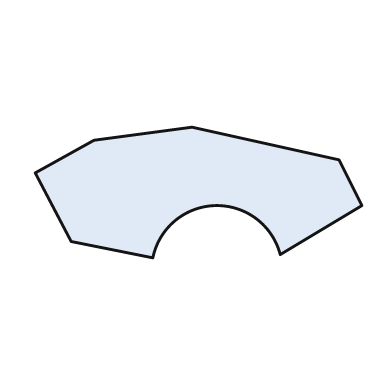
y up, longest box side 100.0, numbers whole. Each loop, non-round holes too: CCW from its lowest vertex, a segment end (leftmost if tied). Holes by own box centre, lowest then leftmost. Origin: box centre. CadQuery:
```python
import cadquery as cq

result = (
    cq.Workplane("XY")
    .moveTo(-14.0, -20.0)
    .threePointArc((5.0, -4.0), (25.0, -19.0))
    .lineTo(50.0, -4.0)
    .lineTo(43.0, 10.0)
    .lineTo(-2.0, 20.0)
    .lineTo(-32.0, 16.0)
    .lineTo(-50.0, 6.0)
    .lineTo(-39.0, -15.0)
    .close()
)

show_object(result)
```